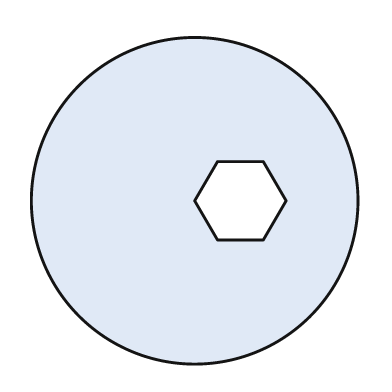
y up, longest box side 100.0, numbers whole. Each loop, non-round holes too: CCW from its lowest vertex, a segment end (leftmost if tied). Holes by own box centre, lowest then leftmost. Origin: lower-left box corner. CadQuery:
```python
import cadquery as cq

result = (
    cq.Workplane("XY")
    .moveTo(50.0, 50.0)
    .circle(50.0)
    .moveTo(57.0, 38.0)
    .lineTo(71.0, 38.0)
    .lineTo(78.0, 50.0)
    .lineTo(71.0, 62.0)
    .lineTo(57.0, 62.0)
    .lineTo(50.0, 50.0)
    .close()
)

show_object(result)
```